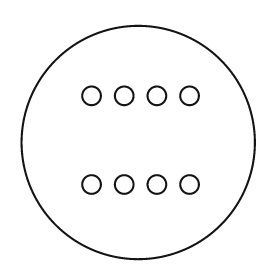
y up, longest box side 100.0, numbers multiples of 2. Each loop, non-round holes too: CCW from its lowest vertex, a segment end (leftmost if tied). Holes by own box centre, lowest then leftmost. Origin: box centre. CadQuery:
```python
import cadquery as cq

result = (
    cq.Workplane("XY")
    .moveTo(0.0, 0.0)
    .circle(50.0)
    .moveTo(-20.0, -18.0)
    .circle(4.0)
    .moveTo(-6.0, -18.0)
    .circle(4.0)
    .moveTo(8.0, -18.0)
    .circle(4.0)
    .moveTo(22.0, -18.0)
    .circle(4.0)
    .moveTo(-20.0, 20.0)
    .circle(4.0)
    .moveTo(-6.0, 20.0)
    .circle(4.0)
    .moveTo(8.0, 20.0)
    .circle(4.0)
    .moveTo(22.0, 20.0)
    .circle(4.0)
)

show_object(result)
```